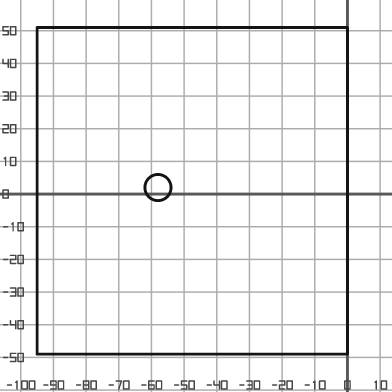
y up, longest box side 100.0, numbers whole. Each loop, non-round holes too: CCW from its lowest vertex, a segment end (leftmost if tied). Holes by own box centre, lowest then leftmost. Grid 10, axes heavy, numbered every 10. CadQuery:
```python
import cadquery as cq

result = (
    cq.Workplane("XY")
    .moveTo(-95.0, -49.0)
    .lineTo(0.0, -49.0)
    .lineTo(0.0, 51.0)
    .lineTo(-95.0, 51.0)
    .close()
    .moveTo(-58.0, 2.0)
    .circle(4.0)
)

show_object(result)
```